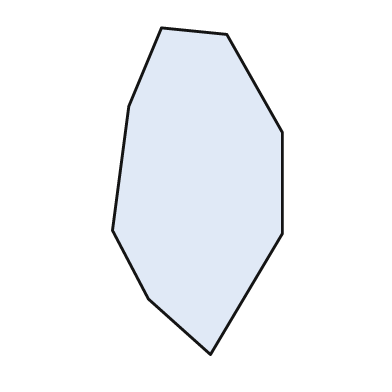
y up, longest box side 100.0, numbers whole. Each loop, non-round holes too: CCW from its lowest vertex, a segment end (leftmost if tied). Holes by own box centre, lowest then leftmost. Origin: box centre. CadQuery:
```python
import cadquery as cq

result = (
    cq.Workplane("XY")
    .moveTo(4.0, -50.0)
    .lineTo(26.0, -13.0)
    .lineTo(26.0, 18.0)
    .lineTo(9.0, 48.0)
    .lineTo(-11.0, 50.0)
    .lineTo(-21.0, 26.0)
    .lineTo(-26.0, -12.0)
    .lineTo(-15.0, -33.0)
    .close()
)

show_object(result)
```